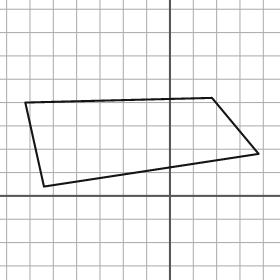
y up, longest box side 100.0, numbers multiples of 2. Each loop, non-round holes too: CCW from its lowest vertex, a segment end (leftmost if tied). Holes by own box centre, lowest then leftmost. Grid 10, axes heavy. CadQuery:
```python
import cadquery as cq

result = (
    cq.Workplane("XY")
    .moveTo(-54.0, 4.0)
    .lineTo(38.0, 18.0)
    .lineTo(18.0, 42.0)
    .lineTo(-62.0, 40.0)
    .close()
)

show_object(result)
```